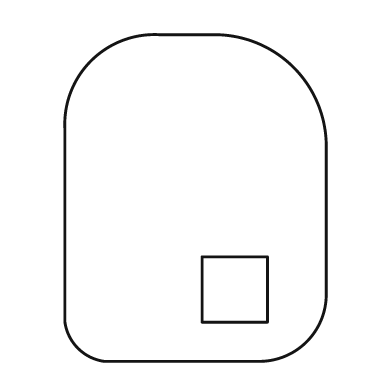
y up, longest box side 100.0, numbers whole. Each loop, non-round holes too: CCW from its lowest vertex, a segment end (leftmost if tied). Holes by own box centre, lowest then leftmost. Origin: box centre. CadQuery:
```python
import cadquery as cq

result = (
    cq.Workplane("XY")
    .moveTo(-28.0, -50.0)
    .lineTo(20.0, -50.0)
    .threePointArc((34.0, -44.0), (40.0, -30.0))
    .lineTo(40.0, 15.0)
    .threePointArc((30.0, 40.0), (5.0, 50.0))
    .lineTo(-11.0, 50.0)
    .threePointArc((-32.0, 42.0), (-40.0, 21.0))
    .lineTo(-40.0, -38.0)
    .threePointArc((-36.0, -46.0), (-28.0, -50.0))
    .close()
    .moveTo(2.0, -38.0)
    .lineTo(22.0, -38.0)
    .lineTo(22.0, -18.0)
    .lineTo(2.0, -18.0)
    .close()
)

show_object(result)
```